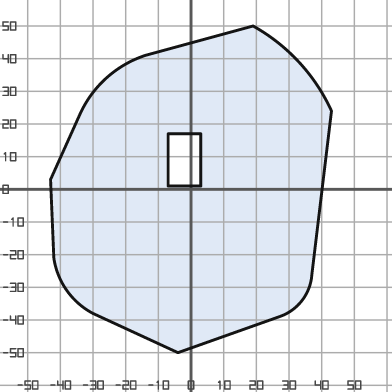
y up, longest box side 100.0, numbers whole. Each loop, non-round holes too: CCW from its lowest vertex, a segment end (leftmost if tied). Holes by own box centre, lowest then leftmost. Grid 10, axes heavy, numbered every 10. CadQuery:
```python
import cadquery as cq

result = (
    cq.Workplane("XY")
    .moveTo(-4.0, -50.0)
    .lineTo(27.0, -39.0)
    .threePointArc((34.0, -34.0), (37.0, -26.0))
    .lineTo(43.0, 24.0)
    .threePointArc((33.0, 39.0), (19.0, 50.0))
    .lineTo(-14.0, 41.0)
    .threePointArc((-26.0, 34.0), (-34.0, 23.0))
    .lineTo(-43.0, 3.0)
    .lineTo(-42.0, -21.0)
    .threePointArc((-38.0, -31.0), (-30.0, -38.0))
    .close()
    .moveTo(-7.0, 1.0)
    .lineTo(3.0, 1.0)
    .lineTo(3.0, 17.0)
    .lineTo(-7.0, 17.0)
    .close()
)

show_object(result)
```